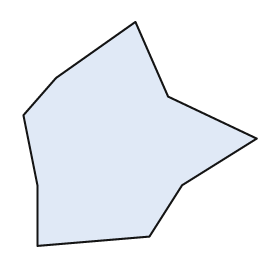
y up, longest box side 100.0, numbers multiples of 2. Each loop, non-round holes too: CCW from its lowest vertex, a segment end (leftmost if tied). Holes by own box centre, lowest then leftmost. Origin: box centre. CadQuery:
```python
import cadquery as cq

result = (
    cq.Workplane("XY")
    .moveTo(-44.0, -48.0)
    .lineTo(4.0, -44.0)
    .lineTo(18.0, -22.0)
    .lineTo(50.0, -2.0)
    .lineTo(12.0, 16.0)
    .lineTo(-2.0, 48.0)
    .lineTo(-36.0, 24.0)
    .lineTo(-50.0, 8.0)
    .lineTo(-44.0, -22.0)
    .close()
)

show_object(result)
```